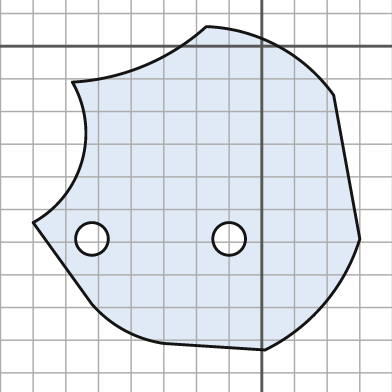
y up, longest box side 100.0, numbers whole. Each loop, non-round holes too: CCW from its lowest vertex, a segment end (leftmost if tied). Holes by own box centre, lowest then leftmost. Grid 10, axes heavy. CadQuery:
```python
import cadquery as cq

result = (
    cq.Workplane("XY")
    .moveTo(1.0, -93.0)
    .threePointArc((19.0, -79.0), (30.0, -59.0))
    .lineTo(22.0, -15.0)
    .threePointArc((5.0, 0.0), (-17.0, 6.0))
    .threePointArc((-36.0, -6.0), (-58.0, -11.0))
    .threePointArc((-55.0, -35.0), (-70.0, -54.0))
    .lineTo(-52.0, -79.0)
    .threePointArc((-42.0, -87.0), (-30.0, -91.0))
    .close()
    .moveTo(-52.0, -59.0)
    .circle(5.0)
    .moveTo(-10.0, -59.0)
    .circle(5.0)
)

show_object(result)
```